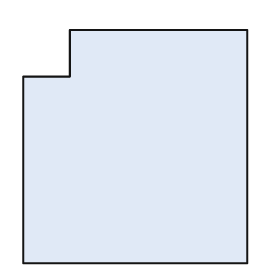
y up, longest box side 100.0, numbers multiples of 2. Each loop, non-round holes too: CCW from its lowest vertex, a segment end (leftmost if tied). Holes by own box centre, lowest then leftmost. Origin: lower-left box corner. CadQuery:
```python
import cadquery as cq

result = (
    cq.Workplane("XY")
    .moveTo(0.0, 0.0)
    .lineTo(96.0, 0.0)
    .lineTo(96.0, 100.0)
    .lineTo(20.0, 100.0)
    .lineTo(20.0, 80.0)
    .lineTo(0.0, 80.0)
    .close()
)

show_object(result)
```